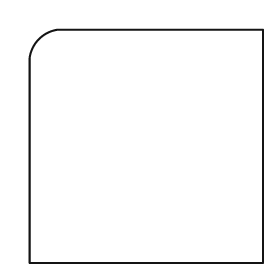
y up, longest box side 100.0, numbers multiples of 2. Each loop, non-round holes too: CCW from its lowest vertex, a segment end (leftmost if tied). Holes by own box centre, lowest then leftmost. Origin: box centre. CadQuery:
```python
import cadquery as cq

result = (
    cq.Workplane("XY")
    .moveTo(-50.0, -50.0)
    .lineTo(50.0, -50.0)
    .lineTo(50.0, 50.0)
    .lineTo(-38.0, 50.0)
    .threePointArc((-46.0, 46.0), (-50.0, 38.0))
    .close()
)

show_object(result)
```